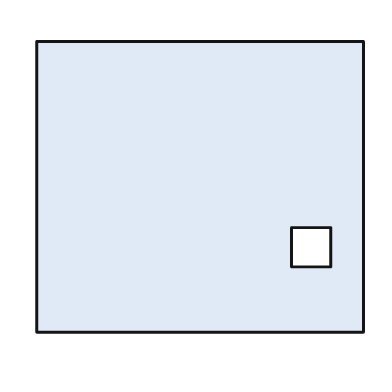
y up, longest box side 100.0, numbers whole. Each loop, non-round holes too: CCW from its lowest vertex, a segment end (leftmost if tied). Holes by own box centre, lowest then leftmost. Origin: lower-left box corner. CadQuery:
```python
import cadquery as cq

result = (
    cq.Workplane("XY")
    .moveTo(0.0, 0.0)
    .lineTo(100.0, 0.0)
    .lineTo(100.0, 89.0)
    .lineTo(0.0, 89.0)
    .close()
    .moveTo(78.0, 20.0)
    .lineTo(90.0, 20.0)
    .lineTo(90.0, 32.0)
    .lineTo(78.0, 32.0)
    .close()
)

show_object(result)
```